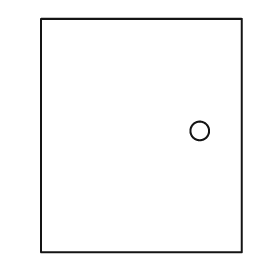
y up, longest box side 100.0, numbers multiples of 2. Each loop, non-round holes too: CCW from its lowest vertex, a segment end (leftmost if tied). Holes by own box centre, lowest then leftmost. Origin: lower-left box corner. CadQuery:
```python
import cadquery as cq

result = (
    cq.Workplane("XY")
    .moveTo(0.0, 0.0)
    .lineTo(86.0, 0.0)
    .lineTo(86.0, 100.0)
    .lineTo(0.0, 100.0)
    .close()
    .moveTo(68.0, 52.0)
    .circle(4.0)
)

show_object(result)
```